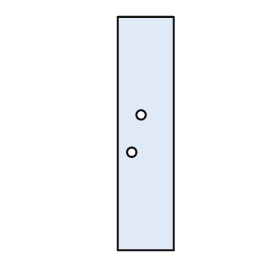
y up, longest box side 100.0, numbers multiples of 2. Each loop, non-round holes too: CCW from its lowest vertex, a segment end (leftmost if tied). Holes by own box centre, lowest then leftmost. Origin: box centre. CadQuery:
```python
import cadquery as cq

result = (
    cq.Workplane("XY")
    .moveTo(-12.0, -50.0)
    .lineTo(12.0, -50.0)
    .lineTo(12.0, 50.0)
    .lineTo(-12.0, 50.0)
    .close()
    .moveTo(-6.0, -8.0)
    .circle(2.0)
    .moveTo(-2.0, 8.0)
    .circle(2.0)
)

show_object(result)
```